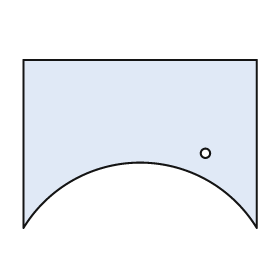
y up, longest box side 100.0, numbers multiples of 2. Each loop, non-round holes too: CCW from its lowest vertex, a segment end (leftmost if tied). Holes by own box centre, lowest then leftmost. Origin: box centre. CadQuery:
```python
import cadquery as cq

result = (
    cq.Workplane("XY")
    .moveTo(-50.0, -36.0)
    .threePointArc((0.0, -8.0), (50.0, -36.0))
    .lineTo(50.0, 36.0)
    .lineTo(-50.0, 36.0)
    .close()
    .moveTo(28.0, -4.0)
    .circle(2.0)
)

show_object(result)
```